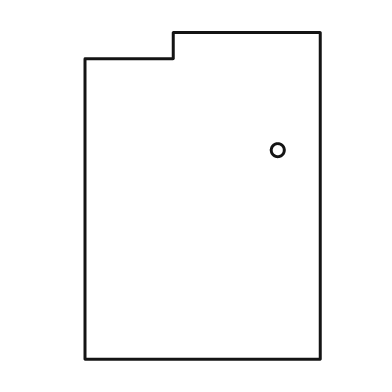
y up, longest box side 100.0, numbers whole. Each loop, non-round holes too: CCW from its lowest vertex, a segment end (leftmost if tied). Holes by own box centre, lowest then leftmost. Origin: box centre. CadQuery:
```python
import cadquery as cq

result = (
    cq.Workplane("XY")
    .moveTo(-36.0, -50.0)
    .lineTo(36.0, -50.0)
    .lineTo(36.0, 50.0)
    .lineTo(-9.0, 50.0)
    .lineTo(-9.0, 42.0)
    .lineTo(-36.0, 42.0)
    .close()
    .moveTo(23.0, 14.0)
    .circle(2.0)
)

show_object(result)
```